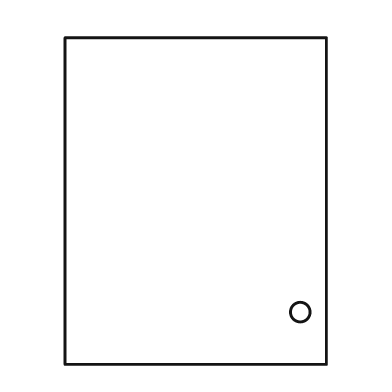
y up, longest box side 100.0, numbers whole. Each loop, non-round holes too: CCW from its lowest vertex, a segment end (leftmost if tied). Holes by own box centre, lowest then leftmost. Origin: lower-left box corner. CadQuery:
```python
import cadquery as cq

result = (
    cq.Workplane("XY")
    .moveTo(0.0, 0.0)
    .lineTo(80.0, 0.0)
    .lineTo(80.0, 100.0)
    .lineTo(0.0, 100.0)
    .close()
    .moveTo(72.0, 16.0)
    .circle(3.0)
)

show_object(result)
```